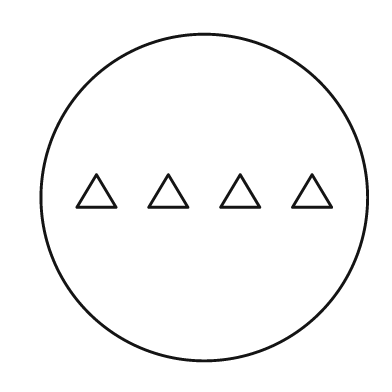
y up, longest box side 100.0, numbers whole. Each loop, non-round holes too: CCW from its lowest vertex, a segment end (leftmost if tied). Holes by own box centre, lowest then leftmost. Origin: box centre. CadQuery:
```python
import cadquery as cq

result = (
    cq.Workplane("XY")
    .moveTo(0.0, 0.0)
    .circle(50.0)
    .moveTo(-39.0, -3.0)
    .lineTo(-27.0, -3.0)
    .lineTo(-33.0, 7.0)
    .close()
    .moveTo(-17.0, -3.0)
    .lineTo(-5.0, -3.0)
    .lineTo(-11.0, 7.0)
    .close()
    .moveTo(5.0, -3.0)
    .lineTo(17.0, -3.0)
    .lineTo(11.0, 7.0)
    .close()
    .moveTo(27.0, -3.0)
    .lineTo(39.0, -3.0)
    .lineTo(33.0, 7.0)
    .close()
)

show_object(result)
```